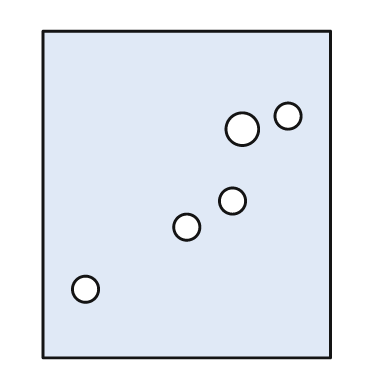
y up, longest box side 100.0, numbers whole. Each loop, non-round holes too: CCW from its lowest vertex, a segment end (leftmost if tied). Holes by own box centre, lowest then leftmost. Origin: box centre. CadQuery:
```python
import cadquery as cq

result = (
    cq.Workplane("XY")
    .moveTo(-44.0, -50.0)
    .lineTo(44.0, -50.0)
    .lineTo(44.0, 50.0)
    .lineTo(-44.0, 50.0)
    .close()
    .moveTo(-31.0, -29.0)
    .circle(4.0)
    .moveTo(0.0, -10.0)
    .circle(4.0)
    .moveTo(14.0, -2.0)
    .circle(4.0)
    .moveTo(17.0, 20.0)
    .circle(5.0)
    .moveTo(31.0, 24.0)
    .circle(4.0)
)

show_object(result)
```